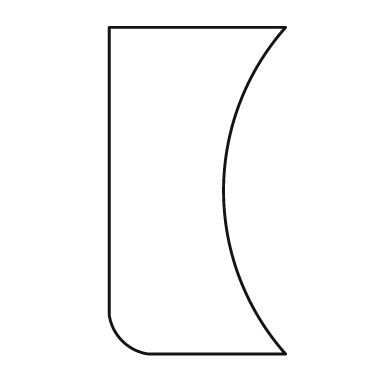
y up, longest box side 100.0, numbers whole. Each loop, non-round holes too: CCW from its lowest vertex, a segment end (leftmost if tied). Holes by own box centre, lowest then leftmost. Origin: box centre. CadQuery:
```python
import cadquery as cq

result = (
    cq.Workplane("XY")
    .moveTo(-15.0, -50.0)
    .lineTo(27.0, -50.0)
    .threePointArc((8.0, 0.0), (27.0, 50.0))
    .lineTo(-27.0, 50.0)
    .lineTo(-27.0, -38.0)
    .threePointArc((-23.0, -46.0), (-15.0, -50.0))
    .close()
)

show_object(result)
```